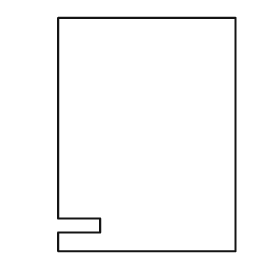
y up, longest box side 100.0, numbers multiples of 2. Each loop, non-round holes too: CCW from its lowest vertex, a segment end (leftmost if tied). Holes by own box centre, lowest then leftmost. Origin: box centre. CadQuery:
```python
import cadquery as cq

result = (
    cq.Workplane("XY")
    .moveTo(-38.0, -50.0)
    .lineTo(38.0, -50.0)
    .lineTo(38.0, 50.0)
    .lineTo(-38.0, 50.0)
    .lineTo(-38.0, -36.0)
    .lineTo(-20.0, -36.0)
    .lineTo(-20.0, -42.0)
    .lineTo(-38.0, -42.0)
    .close()
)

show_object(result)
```